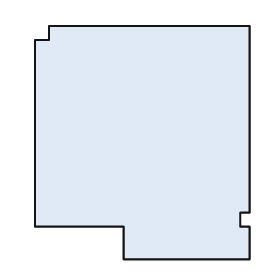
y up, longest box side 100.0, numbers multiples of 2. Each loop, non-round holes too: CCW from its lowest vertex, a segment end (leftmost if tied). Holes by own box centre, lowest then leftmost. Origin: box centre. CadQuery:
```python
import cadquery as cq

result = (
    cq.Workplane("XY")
    .moveTo(-8.0, -50.0)
    .lineTo(46.0, -50.0)
    .lineTo(46.0, -36.0)
    .lineTo(42.0, -36.0)
    .lineTo(42.0, -30.0)
    .lineTo(46.0, -30.0)
    .lineTo(46.0, 50.0)
    .lineTo(-40.0, 50.0)
    .lineTo(-40.0, 44.0)
    .lineTo(-46.0, 44.0)
    .lineTo(-46.0, -36.0)
    .lineTo(-8.0, -36.0)
    .close()
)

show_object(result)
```